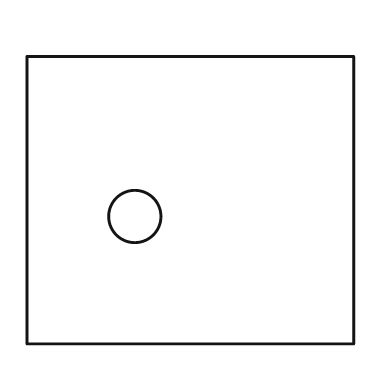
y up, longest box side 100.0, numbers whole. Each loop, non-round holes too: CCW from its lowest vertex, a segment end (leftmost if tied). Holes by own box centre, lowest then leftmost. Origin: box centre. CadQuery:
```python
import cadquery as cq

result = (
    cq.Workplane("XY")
    .moveTo(-50.0, -44.0)
    .lineTo(50.0, -44.0)
    .lineTo(50.0, 44.0)
    .lineTo(-50.0, 44.0)
    .close()
    .moveTo(-17.0, -5.0)
    .circle(8.0)
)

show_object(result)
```